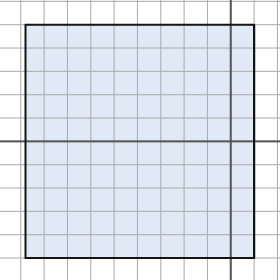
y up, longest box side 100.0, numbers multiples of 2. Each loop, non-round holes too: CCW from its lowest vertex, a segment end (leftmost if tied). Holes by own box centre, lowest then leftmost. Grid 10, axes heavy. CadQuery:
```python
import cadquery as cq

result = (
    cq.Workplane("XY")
    .moveTo(-88.0, -50.0)
    .lineTo(10.0, -50.0)
    .lineTo(10.0, 50.0)
    .lineTo(-88.0, 50.0)
    .close()
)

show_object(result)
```